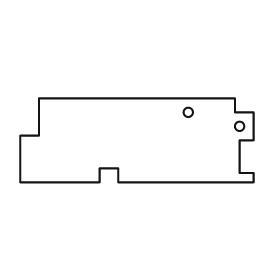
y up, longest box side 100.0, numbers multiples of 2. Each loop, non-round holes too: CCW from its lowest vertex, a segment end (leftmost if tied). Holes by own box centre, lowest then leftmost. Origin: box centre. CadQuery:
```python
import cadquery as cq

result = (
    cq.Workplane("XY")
    .moveTo(-50.0, -18.0)
    .lineTo(-16.0, -18.0)
    .lineTo(-16.0, -12.0)
    .lineTo(-8.0, -12.0)
    .lineTo(-8.0, -18.0)
    .lineTo(50.0, -18.0)
    .lineTo(50.0, -14.0)
    .lineTo(44.0, -14.0)
    .lineTo(44.0, 0.0)
    .lineTo(50.0, 0.0)
    .lineTo(50.0, 12.0)
    .lineTo(42.0, 12.0)
    .lineTo(42.0, 18.0)
    .lineTo(-42.0, 18.0)
    .lineTo(-42.0, 2.0)
    .lineTo(-50.0, 2.0)
    .close()
    .moveTo(44.0, 6.0)
    .circle(2.0)
    .moveTo(22.0, 12.0)
    .circle(2.0)
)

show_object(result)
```